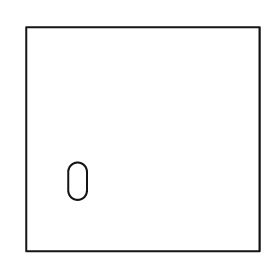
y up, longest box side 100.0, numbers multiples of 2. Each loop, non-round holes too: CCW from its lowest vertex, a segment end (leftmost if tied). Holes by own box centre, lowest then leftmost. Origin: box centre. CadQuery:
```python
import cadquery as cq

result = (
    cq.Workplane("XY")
    .moveTo(-50.0, -48.0)
    .lineTo(50.0, -48.0)
    .lineTo(50.0, 48.0)
    .lineTo(-50.0, 48.0)
    .close()
    .moveTo(-32.0, -22.0)
    .threePointArc((-28.0, -26.0), (-24.0, -22.0))
    .lineTo(-24.0, -14.0)
    .threePointArc((-28.0, -10.0), (-32.0, -14.0))
    .close()
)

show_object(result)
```